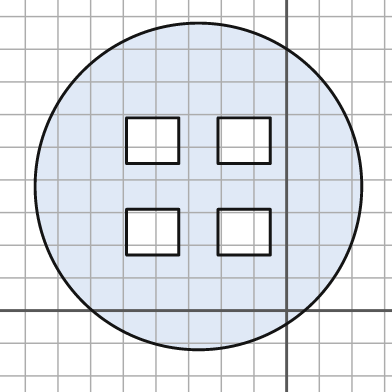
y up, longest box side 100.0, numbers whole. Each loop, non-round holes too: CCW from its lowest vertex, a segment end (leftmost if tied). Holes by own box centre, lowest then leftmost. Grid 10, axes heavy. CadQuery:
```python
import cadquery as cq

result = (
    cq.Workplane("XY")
    .moveTo(-27.0, 38.0)
    .circle(50.0)
    .moveTo(-49.0, 17.0)
    .lineTo(-33.0, 17.0)
    .lineTo(-33.0, 31.0)
    .lineTo(-49.0, 31.0)
    .close()
    .moveTo(-21.0, 17.0)
    .lineTo(-5.0, 17.0)
    .lineTo(-5.0, 31.0)
    .lineTo(-21.0, 31.0)
    .close()
    .moveTo(-49.0, 45.0)
    .lineTo(-33.0, 45.0)
    .lineTo(-33.0, 59.0)
    .lineTo(-49.0, 59.0)
    .close()
    .moveTo(-21.0, 45.0)
    .lineTo(-5.0, 45.0)
    .lineTo(-5.0, 59.0)
    .lineTo(-21.0, 59.0)
    .close()
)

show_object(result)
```